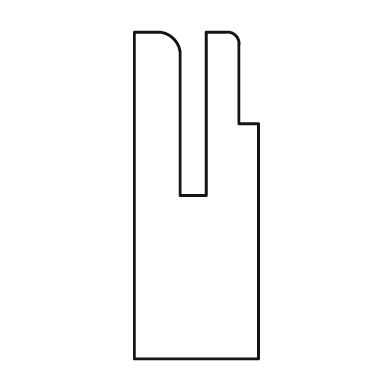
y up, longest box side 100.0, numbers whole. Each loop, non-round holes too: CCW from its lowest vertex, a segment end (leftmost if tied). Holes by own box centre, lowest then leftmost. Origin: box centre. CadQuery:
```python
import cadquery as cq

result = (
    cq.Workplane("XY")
    .moveTo(-19.0, -50.0)
    .lineTo(19.0, -50.0)
    .lineTo(19.0, 22.0)
    .lineTo(13.0, 22.0)
    .lineTo(13.0, 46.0)
    .threePointArc((12.0, 49.0), (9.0, 50.0))
    .lineTo(3.0, 50.0)
    .lineTo(3.0, 0.0)
    .lineTo(-5.0, 0.0)
    .lineTo(-5.0, 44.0)
    .threePointArc((-7.0, 48.0), (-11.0, 50.0))
    .lineTo(-19.0, 50.0)
    .close()
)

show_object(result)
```